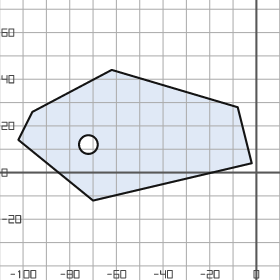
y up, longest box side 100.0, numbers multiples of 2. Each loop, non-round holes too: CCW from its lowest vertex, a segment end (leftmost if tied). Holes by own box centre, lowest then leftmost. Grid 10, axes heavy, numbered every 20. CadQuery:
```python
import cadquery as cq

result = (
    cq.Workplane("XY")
    .moveTo(-70.0, -12.0)
    .lineTo(-2.0, 4.0)
    .lineTo(-8.0, 28.0)
    .lineTo(-62.0, 44.0)
    .lineTo(-96.0, 26.0)
    .lineTo(-102.0, 14.0)
    .close()
    .moveTo(-72.0, 12.0)
    .circle(4.0)
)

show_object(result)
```